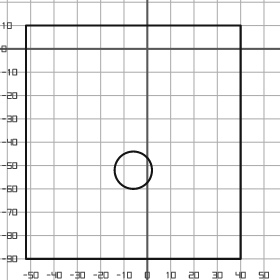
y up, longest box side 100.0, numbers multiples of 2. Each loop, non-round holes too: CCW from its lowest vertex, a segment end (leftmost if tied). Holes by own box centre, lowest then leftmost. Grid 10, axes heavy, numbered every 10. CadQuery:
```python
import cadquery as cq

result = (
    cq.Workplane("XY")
    .moveTo(-52.0, -90.0)
    .lineTo(40.0, -90.0)
    .lineTo(40.0, 10.0)
    .lineTo(-52.0, 10.0)
    .close()
    .moveTo(-6.0, -52.0)
    .circle(8.0)
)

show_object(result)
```